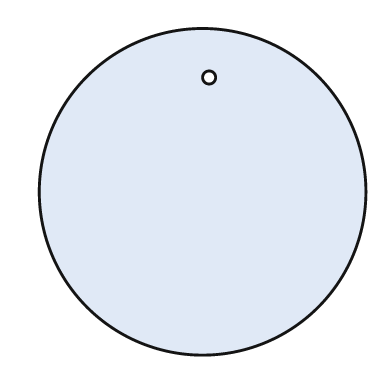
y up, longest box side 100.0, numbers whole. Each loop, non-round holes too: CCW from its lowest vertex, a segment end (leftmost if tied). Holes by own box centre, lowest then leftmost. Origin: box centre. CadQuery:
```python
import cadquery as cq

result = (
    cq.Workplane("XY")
    .moveTo(0.0, 0.0)
    .circle(50.0)
    .moveTo(2.0, 35.0)
    .circle(2.0)
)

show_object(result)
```